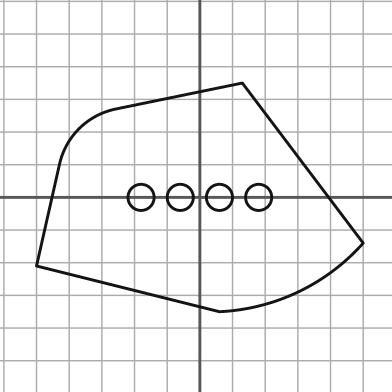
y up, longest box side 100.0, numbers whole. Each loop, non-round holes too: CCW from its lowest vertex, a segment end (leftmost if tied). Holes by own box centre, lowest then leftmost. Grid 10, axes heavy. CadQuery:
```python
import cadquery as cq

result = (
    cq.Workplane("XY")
    .moveTo(6.0, -35.0)
    .threePointArc((30.0, -29.0), (50.0, -14.0))
    .lineTo(13.0, 35.0)
    .lineTo(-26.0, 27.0)
    .threePointArc((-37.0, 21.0), (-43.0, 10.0))
    .lineTo(-50.0, -21.0)
    .close()
    .moveTo(-18.0, 0.0)
    .circle(4.0)
    .moveTo(-6.0, 0.0)
    .circle(4.0)
    .moveTo(6.0, 0.0)
    .circle(4.0)
    .moveTo(18.0, 0.0)
    .circle(4.0)
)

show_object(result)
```